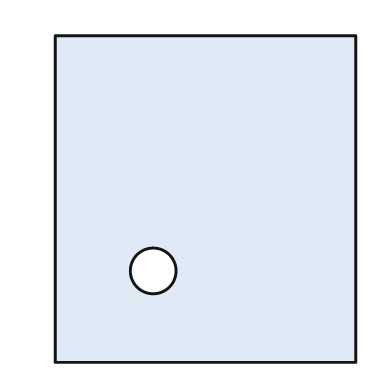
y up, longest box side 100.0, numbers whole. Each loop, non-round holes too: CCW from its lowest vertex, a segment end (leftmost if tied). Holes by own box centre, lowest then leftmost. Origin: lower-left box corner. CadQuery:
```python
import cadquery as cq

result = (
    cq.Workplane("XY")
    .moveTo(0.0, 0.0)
    .lineTo(92.0, 0.0)
    .lineTo(92.0, 100.0)
    .lineTo(0.0, 100.0)
    .close()
    .moveTo(30.0, 28.0)
    .circle(7.0)
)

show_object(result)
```